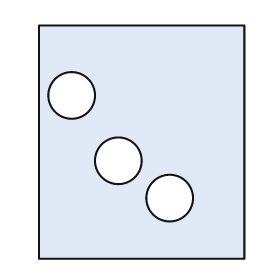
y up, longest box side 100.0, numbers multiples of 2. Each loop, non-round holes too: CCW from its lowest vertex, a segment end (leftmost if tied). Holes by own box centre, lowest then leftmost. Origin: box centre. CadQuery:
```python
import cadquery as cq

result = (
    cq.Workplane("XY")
    .moveTo(-44.0, -50.0)
    .lineTo(44.0, -50.0)
    .lineTo(44.0, 50.0)
    .lineTo(-44.0, 50.0)
    .close()
    .moveTo(12.0, -24.0)
    .circle(10.0)
    .moveTo(-10.0, -8.0)
    .circle(10.0)
    .moveTo(-30.0, 20.0)
    .circle(10.0)
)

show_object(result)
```